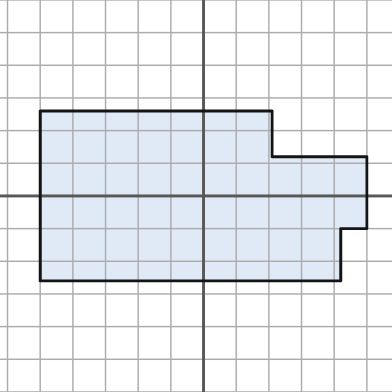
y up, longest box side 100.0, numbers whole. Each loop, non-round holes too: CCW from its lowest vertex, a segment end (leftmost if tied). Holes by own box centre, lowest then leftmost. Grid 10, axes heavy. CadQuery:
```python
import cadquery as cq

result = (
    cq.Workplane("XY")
    .moveTo(-50.0, -26.0)
    .lineTo(42.0, -26.0)
    .lineTo(42.0, -10.0)
    .lineTo(50.0, -10.0)
    .lineTo(50.0, 12.0)
    .lineTo(21.0, 12.0)
    .lineTo(21.0, 26.0)
    .lineTo(-50.0, 26.0)
    .close()
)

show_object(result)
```